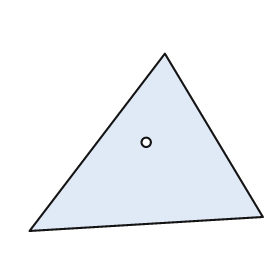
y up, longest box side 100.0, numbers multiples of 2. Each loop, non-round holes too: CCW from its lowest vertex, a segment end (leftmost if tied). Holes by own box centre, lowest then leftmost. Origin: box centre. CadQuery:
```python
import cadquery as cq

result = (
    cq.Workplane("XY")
    .moveTo(-50.0, -38.0)
    .lineTo(50.0, -32.0)
    .lineTo(8.0, 38.0)
    .close()
    .moveTo(0.0, 0.0)
    .circle(2.0)
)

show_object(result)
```